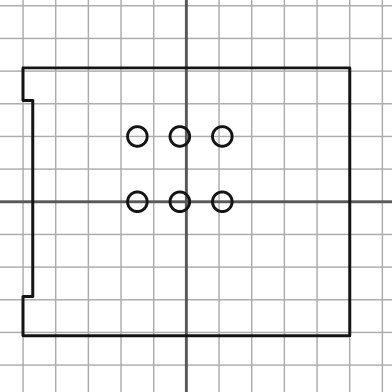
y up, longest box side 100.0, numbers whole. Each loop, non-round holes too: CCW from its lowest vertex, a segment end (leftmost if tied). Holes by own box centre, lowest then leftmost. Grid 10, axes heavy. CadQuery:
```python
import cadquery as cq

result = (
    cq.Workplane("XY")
    .moveTo(-50.0, -41.0)
    .lineTo(50.0, -41.0)
    .lineTo(50.0, 41.0)
    .lineTo(-50.0, 41.0)
    .lineTo(-50.0, 31.0)
    .lineTo(-47.0, 31.0)
    .lineTo(-47.0, -29.0)
    .lineTo(-50.0, -29.0)
    .close()
    .moveTo(-15.0, 0.0)
    .circle(3.0)
    .moveTo(-2.0, 0.0)
    .circle(3.0)
    .moveTo(11.0, 0.0)
    .circle(3.0)
    .moveTo(-15.0, 20.0)
    .circle(3.0)
    .moveTo(-2.0, 20.0)
    .circle(3.0)
    .moveTo(11.0, 20.0)
    .circle(3.0)
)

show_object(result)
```